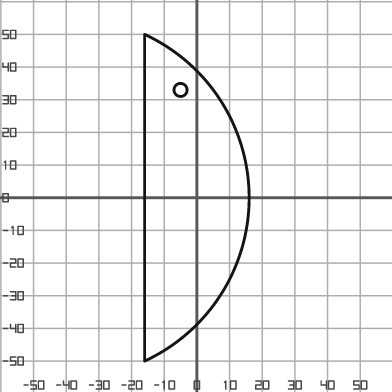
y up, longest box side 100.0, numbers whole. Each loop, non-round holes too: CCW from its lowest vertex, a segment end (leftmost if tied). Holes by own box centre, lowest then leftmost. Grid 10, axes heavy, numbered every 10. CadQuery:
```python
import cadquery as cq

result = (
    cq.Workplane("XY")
    .moveTo(-16.0, -50.0)
    .threePointArc((16.0, 0.0), (-16.0, 50.0))
    .close()
    .moveTo(-5.0, 33.0)
    .circle(2.0)
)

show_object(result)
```